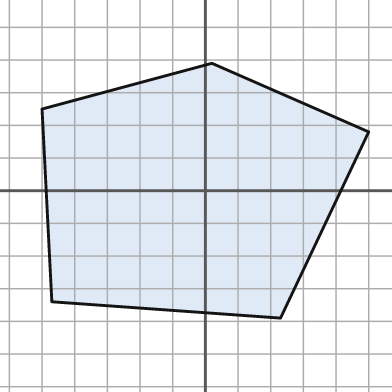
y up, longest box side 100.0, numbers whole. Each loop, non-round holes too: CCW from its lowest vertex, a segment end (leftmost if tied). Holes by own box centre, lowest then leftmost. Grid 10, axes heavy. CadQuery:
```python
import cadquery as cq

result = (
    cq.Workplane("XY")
    .moveTo(23.0, -39.0)
    .lineTo(50.0, 18.0)
    .lineTo(2.0, 39.0)
    .lineTo(-50.0, 25.0)
    .lineTo(-47.0, -34.0)
    .close()
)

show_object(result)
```